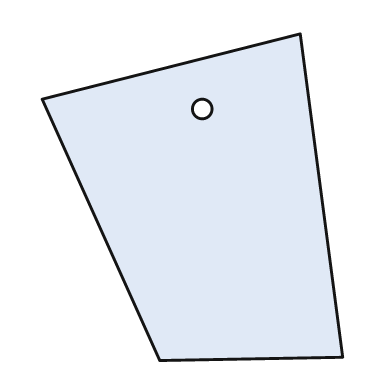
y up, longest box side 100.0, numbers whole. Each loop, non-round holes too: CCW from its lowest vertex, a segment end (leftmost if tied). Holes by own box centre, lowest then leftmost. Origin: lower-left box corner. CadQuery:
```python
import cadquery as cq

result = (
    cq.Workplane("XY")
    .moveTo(36.0, 0.0)
    .lineTo(92.0, 1.0)
    .lineTo(79.0, 100.0)
    .lineTo(0.0, 80.0)
    .close()
    .moveTo(49.0, 77.0)
    .circle(3.0)
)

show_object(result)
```